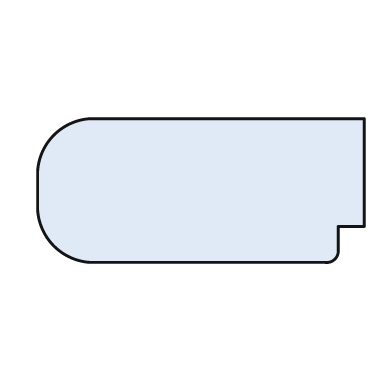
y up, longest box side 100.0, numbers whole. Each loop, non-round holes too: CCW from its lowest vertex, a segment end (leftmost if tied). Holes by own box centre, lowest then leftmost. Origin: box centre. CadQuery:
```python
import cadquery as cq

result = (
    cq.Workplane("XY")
    .moveTo(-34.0, -22.0)
    .lineTo(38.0, -22.0)
    .threePointArc((41.0, -21.0), (42.0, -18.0))
    .lineTo(42.0, -11.0)
    .lineTo(50.0, -11.0)
    .lineTo(50.0, 22.0)
    .lineTo(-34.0, 22.0)
    .threePointArc((-45.0, 17.0), (-50.0, 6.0))
    .lineTo(-50.0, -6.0)
    .threePointArc((-45.0, -17.0), (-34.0, -22.0))
    .close()
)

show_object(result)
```